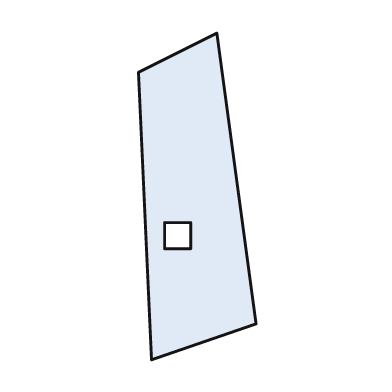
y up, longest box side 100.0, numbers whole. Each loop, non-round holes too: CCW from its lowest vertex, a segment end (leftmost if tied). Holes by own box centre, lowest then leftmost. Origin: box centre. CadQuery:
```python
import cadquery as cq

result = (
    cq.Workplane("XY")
    .moveTo(-14.0, -50.0)
    .lineTo(18.0, -39.0)
    .lineTo(6.0, 50.0)
    .lineTo(-18.0, 38.0)
    .close()
    .moveTo(-10.0, -16.0)
    .lineTo(-2.0, -16.0)
    .lineTo(-2.0, -8.0)
    .lineTo(-10.0, -8.0)
    .close()
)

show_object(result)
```